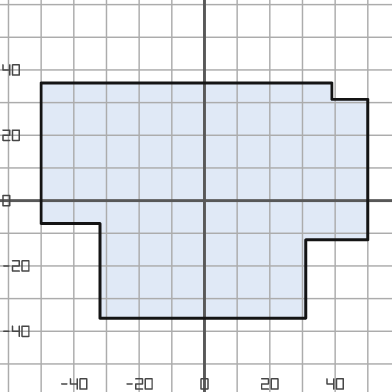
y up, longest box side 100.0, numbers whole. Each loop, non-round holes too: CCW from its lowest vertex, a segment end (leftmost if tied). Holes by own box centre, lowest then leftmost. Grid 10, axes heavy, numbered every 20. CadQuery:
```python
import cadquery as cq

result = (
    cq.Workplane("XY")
    .moveTo(-32.0, -36.0)
    .lineTo(31.0, -36.0)
    .lineTo(31.0, -12.0)
    .lineTo(50.0, -12.0)
    .lineTo(50.0, 31.0)
    .lineTo(39.0, 31.0)
    .lineTo(39.0, 36.0)
    .lineTo(-50.0, 36.0)
    .lineTo(-50.0, -7.0)
    .lineTo(-32.0, -7.0)
    .close()
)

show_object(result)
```